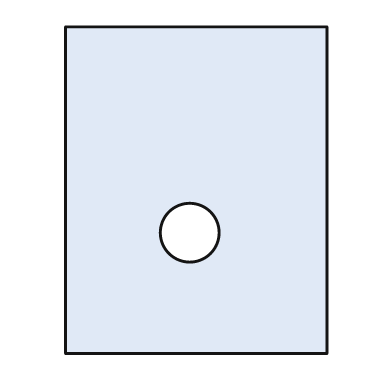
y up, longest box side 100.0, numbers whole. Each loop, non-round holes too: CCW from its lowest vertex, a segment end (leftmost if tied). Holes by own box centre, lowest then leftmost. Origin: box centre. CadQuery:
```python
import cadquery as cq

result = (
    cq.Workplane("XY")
    .moveTo(-40.0, -50.0)
    .lineTo(40.0, -50.0)
    .lineTo(40.0, 50.0)
    .lineTo(-40.0, 50.0)
    .close()
    .moveTo(-2.0, -13.0)
    .circle(9.0)
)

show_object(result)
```